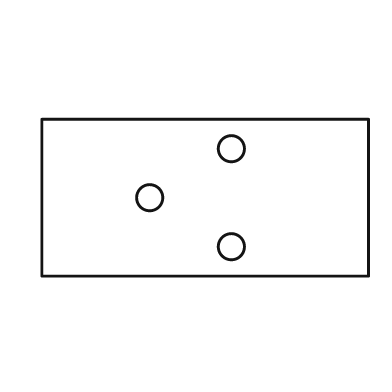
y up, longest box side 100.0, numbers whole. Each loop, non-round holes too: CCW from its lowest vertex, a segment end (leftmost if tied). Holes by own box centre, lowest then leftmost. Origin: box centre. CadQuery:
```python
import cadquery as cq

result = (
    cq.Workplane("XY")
    .moveTo(-50.0, -24.0)
    .lineTo(50.0, -24.0)
    .lineTo(50.0, 24.0)
    .lineTo(-50.0, 24.0)
    .close()
    .moveTo(8.0, -15.0)
    .circle(4.0)
    .moveTo(-17.0, 0.0)
    .circle(4.0)
    .moveTo(8.0, 15.0)
    .circle(4.0)
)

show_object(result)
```